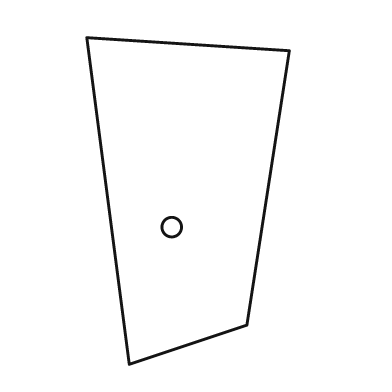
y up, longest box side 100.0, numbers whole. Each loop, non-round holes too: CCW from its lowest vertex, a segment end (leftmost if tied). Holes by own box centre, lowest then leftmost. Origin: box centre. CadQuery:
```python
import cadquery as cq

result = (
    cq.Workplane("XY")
    .moveTo(-18.0, -50.0)
    .lineTo(18.0, -38.0)
    .lineTo(31.0, 46.0)
    .lineTo(-31.0, 50.0)
    .close()
    .moveTo(-5.0, -8.0)
    .circle(3.0)
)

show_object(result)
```